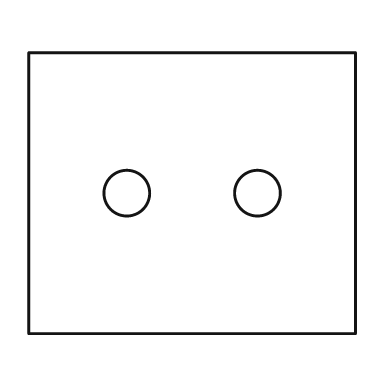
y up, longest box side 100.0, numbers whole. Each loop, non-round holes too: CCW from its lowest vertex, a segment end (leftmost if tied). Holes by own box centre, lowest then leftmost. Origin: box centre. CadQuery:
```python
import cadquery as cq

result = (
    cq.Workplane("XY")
    .moveTo(-50.0, -43.0)
    .lineTo(50.0, -43.0)
    .lineTo(50.0, 43.0)
    .lineTo(-50.0, 43.0)
    .close()
    .moveTo(-20.0, 0.0)
    .circle(7.0)
    .moveTo(20.0, 0.0)
    .circle(7.0)
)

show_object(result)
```